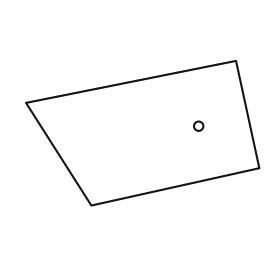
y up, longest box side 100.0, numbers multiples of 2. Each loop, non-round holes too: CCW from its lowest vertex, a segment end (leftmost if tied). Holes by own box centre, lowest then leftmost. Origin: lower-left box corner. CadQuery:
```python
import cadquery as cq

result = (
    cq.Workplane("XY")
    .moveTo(28.0, 0.0)
    .lineTo(100.0, 16.0)
    .lineTo(90.0, 62.0)
    .lineTo(0.0, 44.0)
    .close()
    .moveTo(74.0, 34.0)
    .circle(2.0)
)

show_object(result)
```